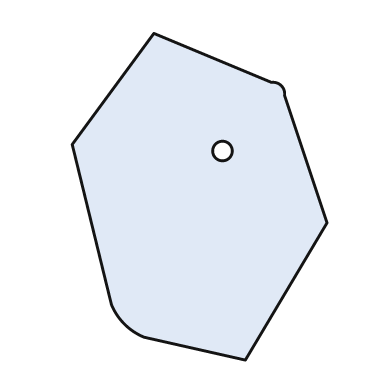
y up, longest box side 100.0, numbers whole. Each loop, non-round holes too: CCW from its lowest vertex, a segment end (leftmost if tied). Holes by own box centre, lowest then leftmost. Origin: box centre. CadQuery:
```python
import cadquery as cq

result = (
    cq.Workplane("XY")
    .moveTo(14.0, -50.0)
    .lineTo(39.0, -8.0)
    .lineTo(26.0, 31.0)
    .threePointArc((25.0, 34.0), (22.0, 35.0))
    .lineTo(-14.0, 50.0)
    .lineTo(-39.0, 16.0)
    .lineTo(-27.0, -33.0)
    .threePointArc((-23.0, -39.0), (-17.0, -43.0))
    .close()
    .moveTo(7.0, 14.0)
    .circle(3.0)
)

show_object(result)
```